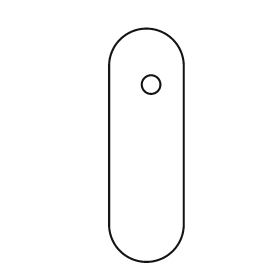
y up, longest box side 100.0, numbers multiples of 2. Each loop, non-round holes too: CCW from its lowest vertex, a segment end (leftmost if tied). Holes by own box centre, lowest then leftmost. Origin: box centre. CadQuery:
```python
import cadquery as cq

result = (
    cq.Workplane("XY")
    .moveTo(-16.0, -34.0)
    .threePointArc((0.0, -50.0), (16.0, -34.0))
    .lineTo(16.0, 34.0)
    .threePointArc((0.0, 50.0), (-16.0, 34.0))
    .close()
    .moveTo(2.0, 26.0)
    .circle(4.0)
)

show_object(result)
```